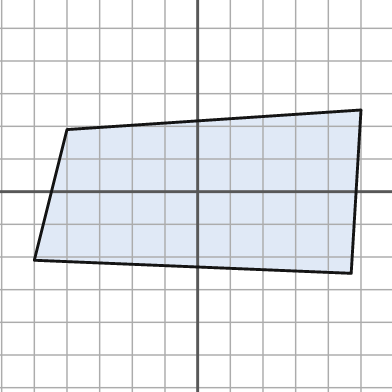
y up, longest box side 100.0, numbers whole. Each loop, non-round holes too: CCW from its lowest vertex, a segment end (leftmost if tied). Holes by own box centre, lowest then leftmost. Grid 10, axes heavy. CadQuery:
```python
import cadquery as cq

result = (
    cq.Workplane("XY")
    .moveTo(47.0, -25.0)
    .lineTo(50.0, 25.0)
    .lineTo(-40.0, 19.0)
    .lineTo(-50.0, -21.0)
    .close()
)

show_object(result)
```